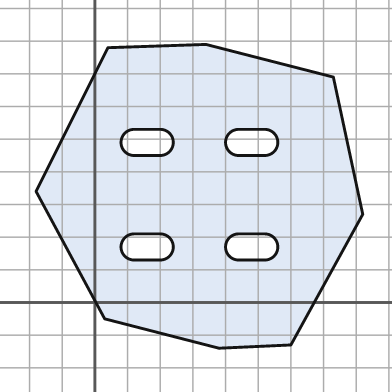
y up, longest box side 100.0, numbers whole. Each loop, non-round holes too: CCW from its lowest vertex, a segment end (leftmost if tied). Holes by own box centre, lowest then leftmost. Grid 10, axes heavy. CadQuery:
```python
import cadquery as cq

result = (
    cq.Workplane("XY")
    .moveTo(38.0, -14.0)
    .lineTo(60.0, -13.0)
    .lineTo(82.0, 27.0)
    .lineTo(73.0, 69.0)
    .lineTo(34.0, 79.0)
    .lineTo(4.0, 78.0)
    .lineTo(-18.0, 34.0)
    .lineTo(3.0, -5.0)
    .close()
    .moveTo(12.0, 13.0)
    .lineTo(20.0, 13.0)
    .threePointArc((24.0, 17.0), (20.0, 21.0))
    .lineTo(12.0, 21.0)
    .threePointArc((8.0, 17.0), (12.0, 13.0))
    .close()
    .moveTo(44.0, 13.0)
    .lineTo(52.0, 13.0)
    .threePointArc((56.0, 17.0), (52.0, 21.0))
    .lineTo(44.0, 21.0)
    .threePointArc((40.0, 17.0), (44.0, 13.0))
    .close()
    .moveTo(12.0, 45.0)
    .lineTo(20.0, 45.0)
    .threePointArc((24.0, 49.0), (20.0, 53.0))
    .lineTo(12.0, 53.0)
    .threePointArc((8.0, 49.0), (12.0, 45.0))
    .close()
    .moveTo(44.0, 45.0)
    .lineTo(52.0, 45.0)
    .threePointArc((56.0, 49.0), (52.0, 53.0))
    .lineTo(44.0, 53.0)
    .threePointArc((40.0, 49.0), (44.0, 45.0))
    .close()
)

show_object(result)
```